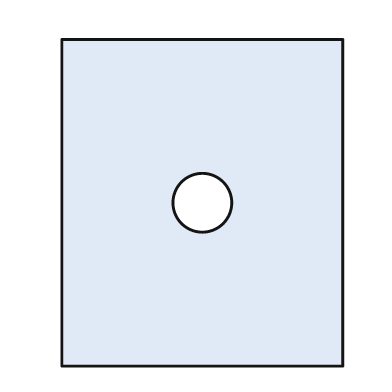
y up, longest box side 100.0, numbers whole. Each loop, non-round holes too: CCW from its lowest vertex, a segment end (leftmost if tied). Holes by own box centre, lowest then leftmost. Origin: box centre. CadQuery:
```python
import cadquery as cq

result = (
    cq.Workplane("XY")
    .moveTo(-43.0, -50.0)
    .lineTo(43.0, -50.0)
    .lineTo(43.0, 50.0)
    .lineTo(-43.0, 50.0)
    .close()
    .moveTo(0.0, 0.0)
    .circle(9.0)
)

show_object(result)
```